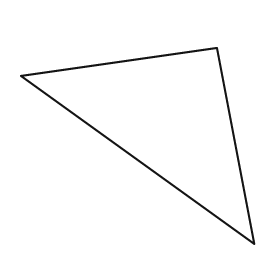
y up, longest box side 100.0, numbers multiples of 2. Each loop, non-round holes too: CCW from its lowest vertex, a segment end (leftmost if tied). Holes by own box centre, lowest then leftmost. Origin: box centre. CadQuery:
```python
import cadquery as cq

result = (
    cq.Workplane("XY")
    .moveTo(50.0, -42.0)
    .lineTo(34.0, 42.0)
    .lineTo(-50.0, 30.0)
    .close()
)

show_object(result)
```